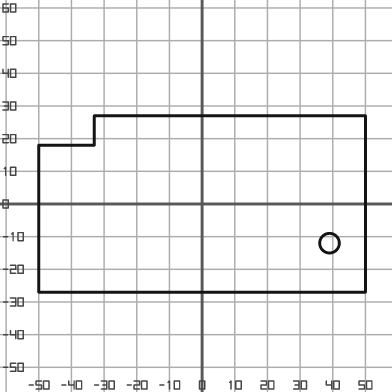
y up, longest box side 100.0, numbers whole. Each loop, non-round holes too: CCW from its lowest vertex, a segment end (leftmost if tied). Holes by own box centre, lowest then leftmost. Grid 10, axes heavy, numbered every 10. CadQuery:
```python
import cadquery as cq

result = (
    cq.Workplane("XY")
    .moveTo(-50.0, -27.0)
    .lineTo(50.0, -27.0)
    .lineTo(50.0, 27.0)
    .lineTo(-33.0, 27.0)
    .lineTo(-33.0, 18.0)
    .lineTo(-50.0, 18.0)
    .close()
    .moveTo(39.0, -12.0)
    .circle(3.0)
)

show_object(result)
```